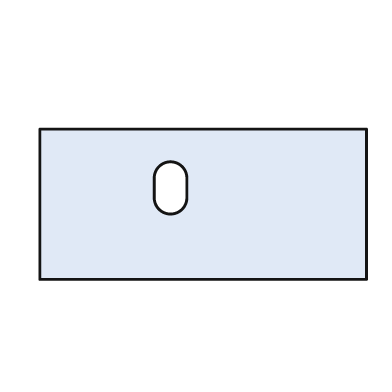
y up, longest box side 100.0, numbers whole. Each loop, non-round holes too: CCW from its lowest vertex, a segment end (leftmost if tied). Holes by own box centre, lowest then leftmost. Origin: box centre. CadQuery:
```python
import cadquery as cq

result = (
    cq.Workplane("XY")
    .moveTo(-50.0, -23.0)
    .lineTo(50.0, -23.0)
    .lineTo(50.0, 23.0)
    .lineTo(-50.0, 23.0)
    .close()
    .moveTo(-15.0, 2.0)
    .threePointArc((-10.0, -3.0), (-5.0, 2.0))
    .lineTo(-5.0, 8.0)
    .threePointArc((-10.0, 13.0), (-15.0, 8.0))
    .close()
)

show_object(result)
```